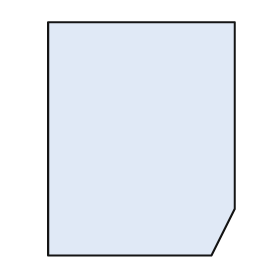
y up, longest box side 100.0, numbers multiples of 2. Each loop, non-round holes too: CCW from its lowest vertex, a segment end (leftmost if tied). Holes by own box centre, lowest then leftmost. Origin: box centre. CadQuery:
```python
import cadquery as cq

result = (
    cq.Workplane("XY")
    .moveTo(-40.0, -50.0)
    .lineTo(30.0, -50.0)
    .lineTo(40.0, -30.0)
    .lineTo(40.0, 50.0)
    .lineTo(-40.0, 50.0)
    .close()
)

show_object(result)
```